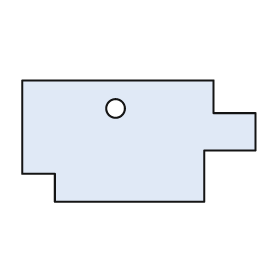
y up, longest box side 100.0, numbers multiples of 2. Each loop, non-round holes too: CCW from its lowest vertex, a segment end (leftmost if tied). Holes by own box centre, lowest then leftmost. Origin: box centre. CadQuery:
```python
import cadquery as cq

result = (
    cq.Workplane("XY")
    .moveTo(-36.0, -26.0)
    .lineTo(28.0, -26.0)
    .lineTo(28.0, -4.0)
    .lineTo(50.0, -4.0)
    .lineTo(50.0, 12.0)
    .lineTo(32.0, 12.0)
    .lineTo(32.0, 26.0)
    .lineTo(-50.0, 26.0)
    .lineTo(-50.0, -14.0)
    .lineTo(-36.0, -14.0)
    .close()
    .moveTo(-10.0, 14.0)
    .circle(4.0)
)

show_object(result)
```